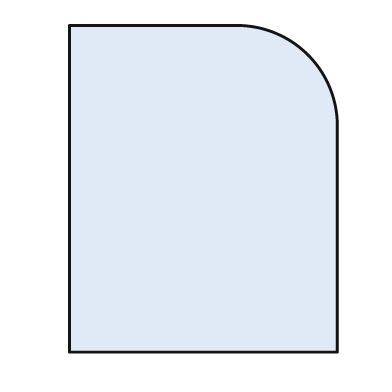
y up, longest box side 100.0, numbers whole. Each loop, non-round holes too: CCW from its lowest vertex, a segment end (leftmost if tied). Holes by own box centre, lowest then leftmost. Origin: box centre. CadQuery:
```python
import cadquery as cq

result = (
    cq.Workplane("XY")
    .moveTo(-41.0, -50.0)
    .lineTo(41.0, -50.0)
    .lineTo(41.0, 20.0)
    .threePointArc((32.0, 41.0), (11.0, 50.0))
    .lineTo(-41.0, 50.0)
    .close()
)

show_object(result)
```